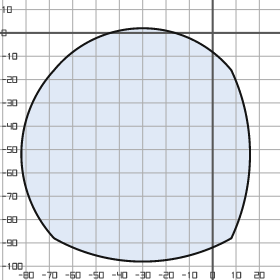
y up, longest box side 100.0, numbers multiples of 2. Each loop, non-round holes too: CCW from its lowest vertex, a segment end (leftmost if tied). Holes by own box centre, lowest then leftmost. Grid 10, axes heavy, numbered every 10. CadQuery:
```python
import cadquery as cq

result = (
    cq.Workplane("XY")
    .moveTo(-68.0, -88.0)
    .threePointArc((-30.0, -98.0), (8.0, -88.0))
    .threePointArc((16.0, -52.0), (8.0, -16.0))
    .threePointArc((-30.0, 2.0), (-68.0, -16.0))
    .threePointArc((-82.0, -52.0), (-68.0, -88.0))
    .close()
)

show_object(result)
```